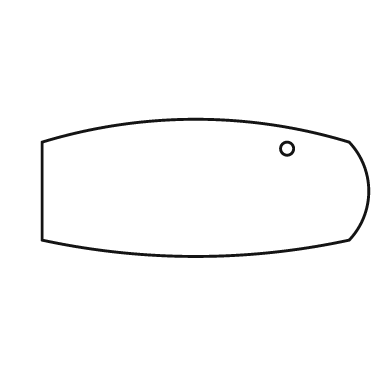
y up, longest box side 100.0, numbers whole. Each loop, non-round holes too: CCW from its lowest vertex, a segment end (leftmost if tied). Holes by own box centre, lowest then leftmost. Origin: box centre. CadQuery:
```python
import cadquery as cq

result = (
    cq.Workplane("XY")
    .moveTo(-50.0, -16.0)
    .threePointArc((-3.0, -21.0), (44.0, -16.0))
    .threePointArc((50.0, -1.0), (44.0, 14.0))
    .threePointArc((-3.0, 21.0), (-50.0, 14.0))
    .close()
    .moveTo(25.0, 12.0)
    .circle(2.0)
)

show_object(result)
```